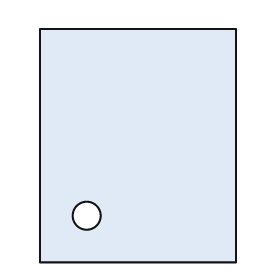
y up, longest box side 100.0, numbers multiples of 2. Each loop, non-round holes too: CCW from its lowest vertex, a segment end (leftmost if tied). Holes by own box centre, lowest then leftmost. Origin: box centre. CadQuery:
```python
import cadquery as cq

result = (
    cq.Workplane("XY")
    .moveTo(-42.0, -50.0)
    .lineTo(42.0, -50.0)
    .lineTo(42.0, 50.0)
    .lineTo(-42.0, 50.0)
    .close()
    .moveTo(-22.0, -30.0)
    .circle(6.0)
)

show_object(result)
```